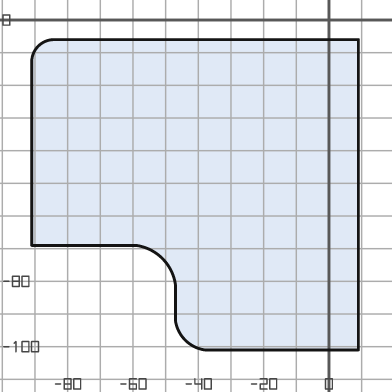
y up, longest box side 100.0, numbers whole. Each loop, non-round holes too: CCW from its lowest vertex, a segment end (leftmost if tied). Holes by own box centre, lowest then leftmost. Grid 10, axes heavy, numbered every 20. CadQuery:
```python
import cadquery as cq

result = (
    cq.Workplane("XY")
    .moveTo(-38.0, -101.0)
    .lineTo(9.0, -101.0)
    .lineTo(9.0, -6.0)
    .lineTo(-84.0, -6.0)
    .threePointArc((-89.0, -8.0), (-91.0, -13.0))
    .lineTo(-91.0, -69.0)
    .lineTo(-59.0, -69.0)
    .threePointArc((-51.0, -73.0), (-47.0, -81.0))
    .lineTo(-47.0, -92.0)
    .threePointArc((-44.0, -98.0), (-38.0, -101.0))
    .close()
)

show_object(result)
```